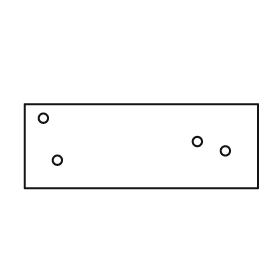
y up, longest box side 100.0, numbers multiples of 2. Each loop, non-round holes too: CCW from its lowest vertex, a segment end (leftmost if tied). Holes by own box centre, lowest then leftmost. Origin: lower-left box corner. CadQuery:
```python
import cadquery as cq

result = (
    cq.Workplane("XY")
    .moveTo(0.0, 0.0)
    .lineTo(100.0, 0.0)
    .lineTo(100.0, 36.0)
    .lineTo(0.0, 36.0)
    .close()
    .moveTo(14.0, 12.0)
    .circle(2.0)
    .moveTo(86.0, 16.0)
    .circle(2.0)
    .moveTo(74.0, 20.0)
    .circle(2.0)
    .moveTo(8.0, 30.0)
    .circle(2.0)
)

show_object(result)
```